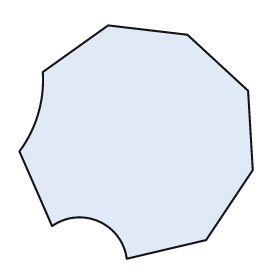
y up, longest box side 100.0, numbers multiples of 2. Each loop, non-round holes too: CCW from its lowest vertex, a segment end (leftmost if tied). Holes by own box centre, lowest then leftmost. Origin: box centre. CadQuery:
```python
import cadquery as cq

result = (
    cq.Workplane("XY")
    .moveTo(-4.0, -50.0)
    .lineTo(30.0, -42.0)
    .lineTo(50.0, -12.0)
    .lineTo(48.0, 22.0)
    .lineTo(22.0, 46.0)
    .lineTo(-12.0, 50.0)
    .lineTo(-40.0, 30.0)
    .threePointArc((-42.0, 12.0), (-50.0, -4.0))
    .lineTo(-36.0, -36.0)
    .threePointArc((-16.0, -34.0), (-4.0, -50.0))
    .close()
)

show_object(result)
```